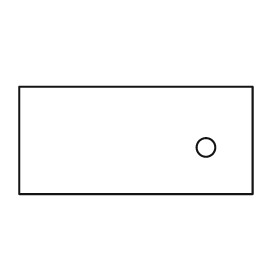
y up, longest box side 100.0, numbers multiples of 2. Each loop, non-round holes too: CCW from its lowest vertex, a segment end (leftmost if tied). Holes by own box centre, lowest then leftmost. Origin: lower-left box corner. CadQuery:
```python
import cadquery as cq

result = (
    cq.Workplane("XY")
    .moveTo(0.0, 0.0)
    .lineTo(100.0, 0.0)
    .lineTo(100.0, 46.0)
    .lineTo(0.0, 46.0)
    .close()
    .moveTo(80.0, 20.0)
    .circle(4.0)
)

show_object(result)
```